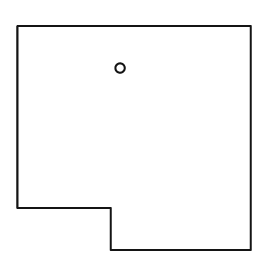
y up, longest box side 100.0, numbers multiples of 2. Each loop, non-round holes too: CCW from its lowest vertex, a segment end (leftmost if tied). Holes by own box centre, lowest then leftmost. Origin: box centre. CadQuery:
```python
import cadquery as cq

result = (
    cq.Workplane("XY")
    .moveTo(-10.0, -48.0)
    .lineTo(50.0, -48.0)
    .lineTo(50.0, 48.0)
    .lineTo(-50.0, 48.0)
    .lineTo(-50.0, -30.0)
    .lineTo(-10.0, -30.0)
    .close()
    .moveTo(-6.0, 30.0)
    .circle(2.0)
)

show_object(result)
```